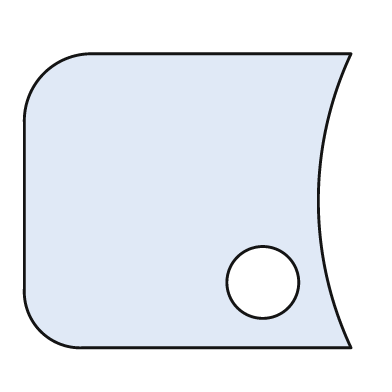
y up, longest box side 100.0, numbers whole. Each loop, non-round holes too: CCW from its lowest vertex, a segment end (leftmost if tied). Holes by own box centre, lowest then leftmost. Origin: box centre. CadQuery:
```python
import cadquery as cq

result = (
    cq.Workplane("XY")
    .moveTo(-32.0, -45.0)
    .lineTo(50.0, -45.0)
    .threePointArc((40.0, 0.0), (50.0, 45.0))
    .lineTo(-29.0, 45.0)
    .threePointArc((-44.0, 39.0), (-50.0, 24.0))
    .lineTo(-50.0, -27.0)
    .threePointArc((-45.0, -40.0), (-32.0, -45.0))
    .close()
    .moveTo(23.0, -25.0)
    .circle(11.0)
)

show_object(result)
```